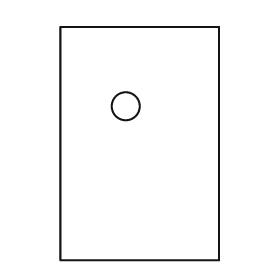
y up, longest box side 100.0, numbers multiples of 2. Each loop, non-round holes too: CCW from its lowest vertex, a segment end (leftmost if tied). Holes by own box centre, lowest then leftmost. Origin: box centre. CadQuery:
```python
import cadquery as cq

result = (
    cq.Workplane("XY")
    .moveTo(-34.0, -50.0)
    .lineTo(34.0, -50.0)
    .lineTo(34.0, 50.0)
    .lineTo(-34.0, 50.0)
    .close()
    .moveTo(-6.0, 16.0)
    .circle(6.0)
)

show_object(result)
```